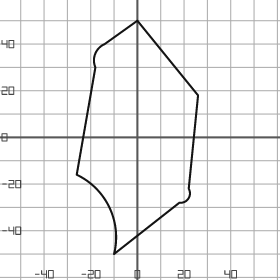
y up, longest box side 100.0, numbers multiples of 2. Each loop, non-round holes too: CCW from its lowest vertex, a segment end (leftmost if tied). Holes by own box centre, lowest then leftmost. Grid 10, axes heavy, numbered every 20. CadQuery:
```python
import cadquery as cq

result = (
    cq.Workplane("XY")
    .moveTo(-10.0, -50.0)
    .lineTo(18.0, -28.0)
    .threePointArc((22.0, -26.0), (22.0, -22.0))
    .lineTo(26.0, 18.0)
    .lineTo(0.0, 50.0)
    .lineTo(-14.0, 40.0)
    .threePointArc((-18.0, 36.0), (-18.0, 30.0))
    .lineTo(-26.0, -16.0)
    .threePointArc((-12.0, -30.0), (-10.0, -50.0))
    .close()
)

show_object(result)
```